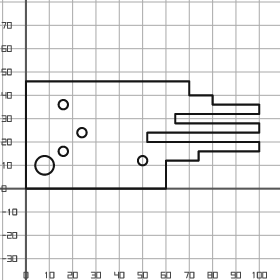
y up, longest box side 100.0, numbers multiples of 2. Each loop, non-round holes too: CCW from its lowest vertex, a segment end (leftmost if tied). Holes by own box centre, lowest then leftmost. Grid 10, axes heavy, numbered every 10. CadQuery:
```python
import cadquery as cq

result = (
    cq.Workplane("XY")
    .moveTo(0.0, 0.0)
    .lineTo(60.0, 0.0)
    .lineTo(60.0, 12.0)
    .lineTo(74.0, 12.0)
    .lineTo(74.0, 16.0)
    .lineTo(100.0, 16.0)
    .lineTo(100.0, 20.0)
    .lineTo(52.0, 20.0)
    .lineTo(52.0, 24.0)
    .lineTo(100.0, 24.0)
    .lineTo(100.0, 28.0)
    .lineTo(64.0, 28.0)
    .lineTo(64.0, 32.0)
    .lineTo(100.0, 32.0)
    .lineTo(100.0, 36.0)
    .lineTo(80.0, 36.0)
    .lineTo(80.0, 40.0)
    .lineTo(70.0, 40.0)
    .lineTo(70.0, 46.0)
    .lineTo(0.0, 46.0)
    .close()
    .moveTo(8.0, 10.0)
    .circle(4.0)
    .moveTo(50.0, 12.0)
    .circle(2.0)
    .moveTo(16.0, 16.0)
    .circle(2.0)
    .moveTo(24.0, 24.0)
    .circle(2.0)
    .moveTo(16.0, 36.0)
    .circle(2.0)
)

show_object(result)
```